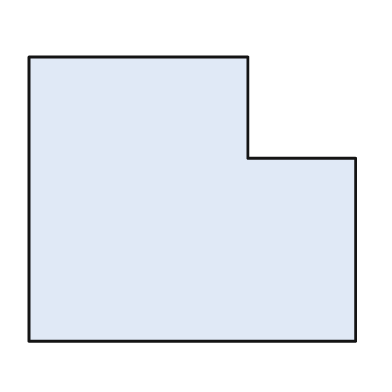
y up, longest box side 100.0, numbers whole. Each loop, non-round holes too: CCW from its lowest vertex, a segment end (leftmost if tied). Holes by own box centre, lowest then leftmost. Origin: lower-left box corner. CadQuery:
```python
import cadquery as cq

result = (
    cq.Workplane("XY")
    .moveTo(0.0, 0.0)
    .lineTo(100.0, 0.0)
    .lineTo(100.0, 56.0)
    .lineTo(67.0, 56.0)
    .lineTo(67.0, 87.0)
    .lineTo(0.0, 87.0)
    .close()
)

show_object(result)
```